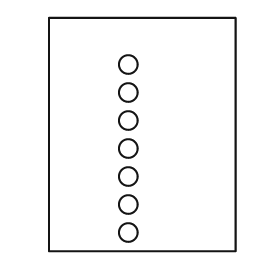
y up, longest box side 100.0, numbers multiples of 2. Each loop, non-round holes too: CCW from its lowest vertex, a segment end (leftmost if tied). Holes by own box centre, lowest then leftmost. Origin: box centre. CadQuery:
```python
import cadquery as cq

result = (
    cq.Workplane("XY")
    .moveTo(-40.0, -50.0)
    .lineTo(40.0, -50.0)
    .lineTo(40.0, 50.0)
    .lineTo(-40.0, 50.0)
    .close()
    .moveTo(-6.0, -42.0)
    .circle(4.0)
    .moveTo(-6.0, -30.0)
    .circle(4.0)
    .moveTo(-6.0, -18.0)
    .circle(4.0)
    .moveTo(-6.0, -6.0)
    .circle(4.0)
    .moveTo(-6.0, 6.0)
    .circle(4.0)
    .moveTo(-6.0, 18.0)
    .circle(4.0)
    .moveTo(-6.0, 30.0)
    .circle(4.0)
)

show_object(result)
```